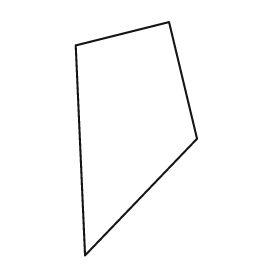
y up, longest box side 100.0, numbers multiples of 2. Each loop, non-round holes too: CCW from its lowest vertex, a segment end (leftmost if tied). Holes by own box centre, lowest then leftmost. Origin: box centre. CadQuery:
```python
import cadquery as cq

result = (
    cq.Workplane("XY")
    .moveTo(-22.0, -50.0)
    .lineTo(26.0, 0.0)
    .lineTo(14.0, 50.0)
    .lineTo(-26.0, 40.0)
    .close()
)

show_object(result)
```